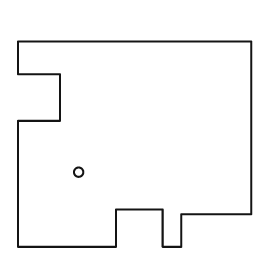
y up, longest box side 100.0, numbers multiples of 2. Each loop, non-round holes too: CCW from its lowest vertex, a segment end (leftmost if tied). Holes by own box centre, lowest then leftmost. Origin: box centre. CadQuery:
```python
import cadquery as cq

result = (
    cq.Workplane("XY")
    .moveTo(-50.0, -44.0)
    .lineTo(-8.0, -44.0)
    .lineTo(-8.0, -28.0)
    .lineTo(12.0, -28.0)
    .lineTo(12.0, -44.0)
    .lineTo(20.0, -44.0)
    .lineTo(20.0, -30.0)
    .lineTo(50.0, -30.0)
    .lineTo(50.0, 44.0)
    .lineTo(-50.0, 44.0)
    .lineTo(-50.0, 30.0)
    .lineTo(-32.0, 30.0)
    .lineTo(-32.0, 10.0)
    .lineTo(-50.0, 10.0)
    .close()
    .moveTo(-24.0, -12.0)
    .circle(2.0)
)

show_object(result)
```